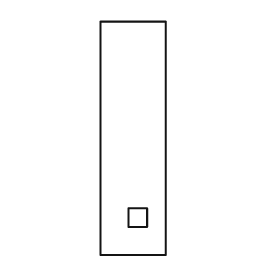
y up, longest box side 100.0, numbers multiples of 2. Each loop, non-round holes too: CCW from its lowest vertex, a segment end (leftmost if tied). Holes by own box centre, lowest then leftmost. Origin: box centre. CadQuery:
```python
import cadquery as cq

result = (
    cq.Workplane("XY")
    .moveTo(-14.0, -50.0)
    .lineTo(14.0, -50.0)
    .lineTo(14.0, 50.0)
    .lineTo(-14.0, 50.0)
    .close()
    .moveTo(-2.0, -38.0)
    .lineTo(6.0, -38.0)
    .lineTo(6.0, -30.0)
    .lineTo(-2.0, -30.0)
    .close()
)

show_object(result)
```